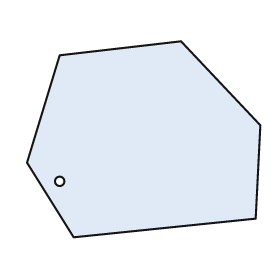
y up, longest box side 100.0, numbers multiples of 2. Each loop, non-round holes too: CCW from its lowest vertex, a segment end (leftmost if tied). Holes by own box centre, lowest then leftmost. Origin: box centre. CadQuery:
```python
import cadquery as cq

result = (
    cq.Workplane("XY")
    .moveTo(-30.0, -42.0)
    .lineTo(48.0, -34.0)
    .lineTo(50.0, 6.0)
    .lineTo(16.0, 42.0)
    .lineTo(-36.0, 36.0)
    .lineTo(-50.0, -10.0)
    .close()
    .moveTo(-36.0, -18.0)
    .circle(2.0)
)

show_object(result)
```